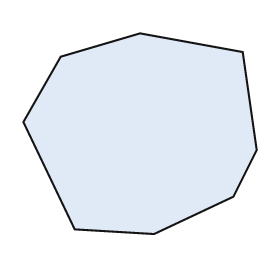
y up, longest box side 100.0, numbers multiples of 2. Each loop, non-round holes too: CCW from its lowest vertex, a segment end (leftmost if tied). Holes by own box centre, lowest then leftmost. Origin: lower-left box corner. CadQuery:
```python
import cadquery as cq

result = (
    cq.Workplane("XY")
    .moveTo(56.0, 0.0)
    .lineTo(90.0, 16.0)
    .lineTo(100.0, 36.0)
    .lineTo(94.0, 78.0)
    .lineTo(50.0, 86.0)
    .lineTo(16.0, 76.0)
    .lineTo(0.0, 48.0)
    .lineTo(22.0, 2.0)
    .close()
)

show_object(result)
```